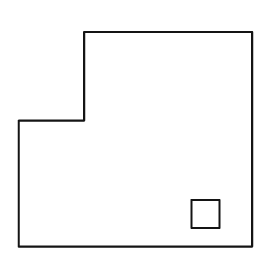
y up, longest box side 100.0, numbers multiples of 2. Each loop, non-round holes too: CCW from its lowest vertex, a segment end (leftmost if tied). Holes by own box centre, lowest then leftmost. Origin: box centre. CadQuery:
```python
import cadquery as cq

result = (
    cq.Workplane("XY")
    .moveTo(-50.0, -46.0)
    .lineTo(50.0, -46.0)
    .lineTo(50.0, 46.0)
    .lineTo(-22.0, 46.0)
    .lineTo(-22.0, 8.0)
    .lineTo(-50.0, 8.0)
    .close()
    .moveTo(24.0, -38.0)
    .lineTo(36.0, -38.0)
    .lineTo(36.0, -26.0)
    .lineTo(24.0, -26.0)
    .close()
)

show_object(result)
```